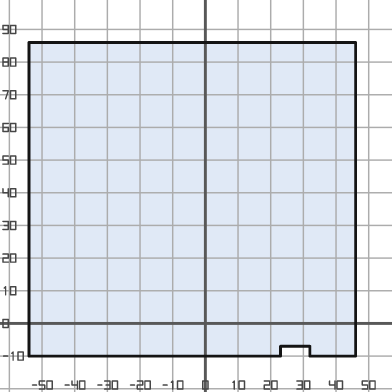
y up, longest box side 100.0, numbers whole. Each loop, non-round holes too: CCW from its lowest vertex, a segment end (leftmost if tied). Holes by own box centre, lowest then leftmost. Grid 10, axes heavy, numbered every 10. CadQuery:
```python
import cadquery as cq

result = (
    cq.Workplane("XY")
    .moveTo(-54.0, -10.0)
    .lineTo(23.0, -10.0)
    .lineTo(23.0, -7.0)
    .lineTo(32.0, -7.0)
    .lineTo(32.0, -10.0)
    .lineTo(46.0, -10.0)
    .lineTo(46.0, 86.0)
    .lineTo(-54.0, 86.0)
    .close()
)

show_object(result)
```